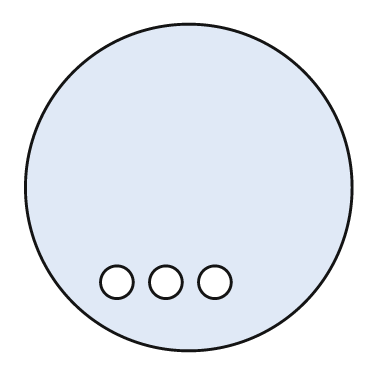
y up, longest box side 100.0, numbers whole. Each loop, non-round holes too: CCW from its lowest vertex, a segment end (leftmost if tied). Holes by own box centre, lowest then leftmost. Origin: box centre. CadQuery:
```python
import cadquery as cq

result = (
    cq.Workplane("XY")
    .moveTo(0.0, 0.0)
    .circle(50.0)
    .moveTo(-22.0, -29.0)
    .circle(5.0)
    .moveTo(-7.0, -29.0)
    .circle(5.0)
    .moveTo(8.0, -29.0)
    .circle(5.0)
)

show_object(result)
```